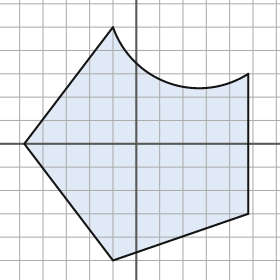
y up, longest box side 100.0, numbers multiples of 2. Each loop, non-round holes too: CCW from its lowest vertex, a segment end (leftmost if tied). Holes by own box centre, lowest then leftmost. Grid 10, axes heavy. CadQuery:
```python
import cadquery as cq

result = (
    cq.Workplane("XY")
    .moveTo(-10.0, -50.0)
    .lineTo(48.0, -30.0)
    .lineTo(48.0, 30.0)
    .threePointArc((14.0, 26.0), (-10.0, 50.0))
    .lineTo(-48.0, 0.0)
    .close()
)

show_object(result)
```